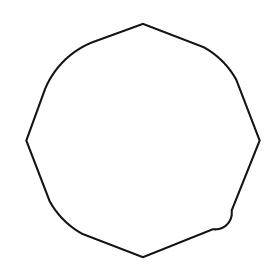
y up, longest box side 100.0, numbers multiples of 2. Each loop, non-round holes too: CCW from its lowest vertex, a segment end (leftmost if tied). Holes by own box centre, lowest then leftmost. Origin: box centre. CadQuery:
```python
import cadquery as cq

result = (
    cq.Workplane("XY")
    .moveTo(0.0, -50.0)
    .lineTo(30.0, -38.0)
    .threePointArc((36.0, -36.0), (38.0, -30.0))
    .lineTo(50.0, 0.0)
    .lineTo(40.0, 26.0)
    .threePointArc((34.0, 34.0), (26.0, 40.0))
    .lineTo(0.0, 50.0)
    .lineTo(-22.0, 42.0)
    .threePointArc((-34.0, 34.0), (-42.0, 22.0))
    .lineTo(-50.0, 0.0)
    .lineTo(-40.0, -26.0)
    .threePointArc((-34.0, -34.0), (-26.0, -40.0))
    .close()
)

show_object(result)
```